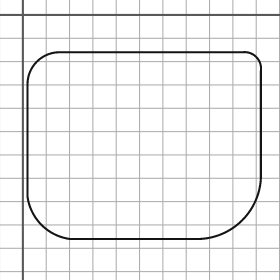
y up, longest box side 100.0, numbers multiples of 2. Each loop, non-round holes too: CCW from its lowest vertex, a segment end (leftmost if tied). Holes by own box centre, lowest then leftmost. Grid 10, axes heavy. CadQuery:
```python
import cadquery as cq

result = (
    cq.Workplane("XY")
    .moveTo(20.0, -96.0)
    .lineTo(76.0, -96.0)
    .threePointArc((94.0, -88.0), (102.0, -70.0))
    .lineTo(102.0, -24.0)
    .threePointArc((100.0, -18.0), (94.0, -16.0))
    .lineTo(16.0, -16.0)
    .threePointArc((6.0, -20.0), (2.0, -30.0))
    .lineTo(2.0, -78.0)
    .threePointArc((8.0, -90.0), (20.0, -96.0))
    .close()
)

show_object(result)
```